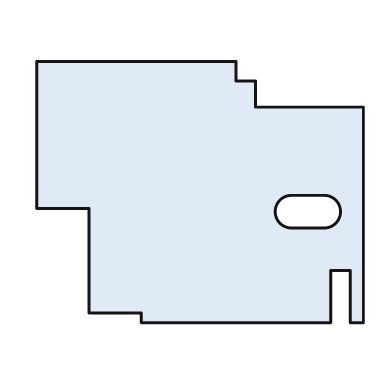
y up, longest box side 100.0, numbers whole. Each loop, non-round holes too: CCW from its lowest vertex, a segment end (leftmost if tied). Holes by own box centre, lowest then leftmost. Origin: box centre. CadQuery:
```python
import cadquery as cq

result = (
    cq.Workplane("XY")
    .moveTo(-18.0, -40.0)
    .lineTo(40.0, -40.0)
    .lineTo(40.0, -24.0)
    .lineTo(46.0, -24.0)
    .lineTo(46.0, -40.0)
    .lineTo(50.0, -40.0)
    .lineTo(50.0, 26.0)
    .lineTo(17.0, 26.0)
    .lineTo(17.0, 34.0)
    .lineTo(11.0, 34.0)
    .lineTo(11.0, 40.0)
    .lineTo(-50.0, 40.0)
    .lineTo(-50.0, -5.0)
    .lineTo(-34.0, -5.0)
    .lineTo(-34.0, -37.0)
    .lineTo(-18.0, -37.0)
    .close()
    .moveTo(28.0, -11.0)
    .lineTo(38.0, -11.0)
    .threePointArc((43.0, -6.0), (38.0, -1.0))
    .lineTo(28.0, -1.0)
    .threePointArc((23.0, -6.0), (28.0, -11.0))
    .close()
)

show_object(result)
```